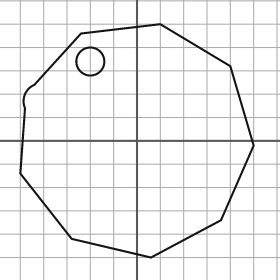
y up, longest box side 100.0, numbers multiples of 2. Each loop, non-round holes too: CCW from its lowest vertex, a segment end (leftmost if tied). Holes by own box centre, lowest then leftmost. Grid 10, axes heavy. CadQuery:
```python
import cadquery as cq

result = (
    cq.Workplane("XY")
    .moveTo(6.0, -50.0)
    .lineTo(36.0, -34.0)
    .lineTo(50.0, -2.0)
    .lineTo(40.0, 32.0)
    .lineTo(10.0, 50.0)
    .lineTo(-24.0, 46.0)
    .lineTo(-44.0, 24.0)
    .threePointArc((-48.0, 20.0), (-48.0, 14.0))
    .lineTo(-50.0, -14.0)
    .lineTo(-28.0, -42.0)
    .close()
    .moveTo(-20.0, 34.0)
    .circle(6.0)
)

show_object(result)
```